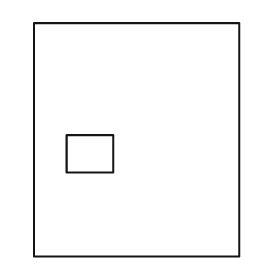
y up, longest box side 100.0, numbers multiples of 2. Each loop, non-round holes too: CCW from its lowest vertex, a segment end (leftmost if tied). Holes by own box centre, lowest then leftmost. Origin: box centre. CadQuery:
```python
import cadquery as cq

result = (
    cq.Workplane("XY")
    .moveTo(-44.0, -50.0)
    .lineTo(44.0, -50.0)
    .lineTo(44.0, 50.0)
    .lineTo(-44.0, 50.0)
    .close()
    .moveTo(-30.0, -14.0)
    .lineTo(-10.0, -14.0)
    .lineTo(-10.0, 2.0)
    .lineTo(-30.0, 2.0)
    .close()
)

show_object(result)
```